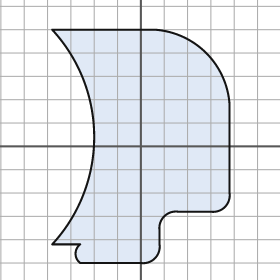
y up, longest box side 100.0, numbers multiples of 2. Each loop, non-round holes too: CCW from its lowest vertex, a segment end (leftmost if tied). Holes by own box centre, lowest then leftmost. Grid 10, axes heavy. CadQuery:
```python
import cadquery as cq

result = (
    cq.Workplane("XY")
    .moveTo(-26.0, -50.0)
    .lineTo(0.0, -50.0)
    .threePointArc((6.0, -48.0), (8.0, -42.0))
    .lineTo(8.0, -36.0)
    .threePointArc((10.0, -30.0), (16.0, -28.0))
    .lineTo(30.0, -28.0)
    .threePointArc((36.0, -26.0), (38.0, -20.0))
    .lineTo(38.0, 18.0)
    .threePointArc((28.0, 40.0), (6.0, 50.0))
    .lineTo(-38.0, 50.0)
    .threePointArc((-20.0, 4.0), (-38.0, -42.0))
    .lineTo(-26.0, -42.0)
    .threePointArc((-28.0, -46.0), (-26.0, -50.0))
    .close()
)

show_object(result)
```